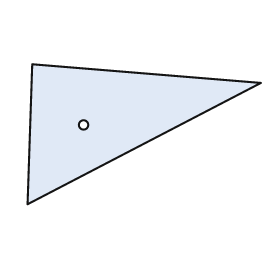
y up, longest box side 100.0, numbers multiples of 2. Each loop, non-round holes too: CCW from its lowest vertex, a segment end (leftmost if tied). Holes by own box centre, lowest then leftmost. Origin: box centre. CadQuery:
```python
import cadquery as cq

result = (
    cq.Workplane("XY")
    .moveTo(-50.0, -30.0)
    .lineTo(50.0, 22.0)
    .lineTo(-48.0, 30.0)
    .close()
    .moveTo(-26.0, 4.0)
    .circle(2.0)
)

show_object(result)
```